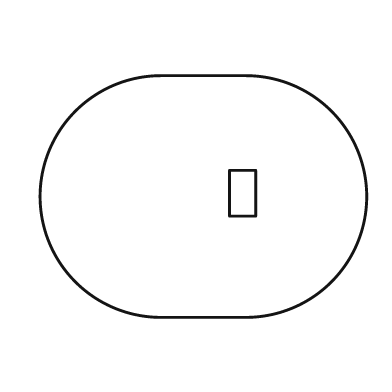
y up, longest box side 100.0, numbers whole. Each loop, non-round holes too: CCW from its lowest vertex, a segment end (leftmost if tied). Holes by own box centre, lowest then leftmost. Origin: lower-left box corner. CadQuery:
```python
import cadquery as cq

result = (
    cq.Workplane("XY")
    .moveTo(37.0, 0.0)
    .lineTo(63.0, 0.0)
    .threePointArc((100.0, 37.0), (63.0, 74.0))
    .lineTo(37.0, 74.0)
    .threePointArc((0.0, 37.0), (37.0, 0.0))
    .close()
    .moveTo(58.0, 31.0)
    .lineTo(66.0, 31.0)
    .lineTo(66.0, 45.0)
    .lineTo(58.0, 45.0)
    .close()
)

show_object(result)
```